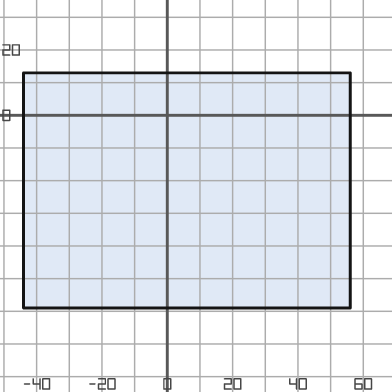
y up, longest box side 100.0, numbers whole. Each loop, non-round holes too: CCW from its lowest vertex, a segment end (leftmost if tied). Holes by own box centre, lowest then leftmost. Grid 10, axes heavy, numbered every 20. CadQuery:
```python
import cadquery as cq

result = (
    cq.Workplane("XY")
    .moveTo(-44.0, -59.0)
    .lineTo(56.0, -59.0)
    .lineTo(56.0, 13.0)
    .lineTo(-44.0, 13.0)
    .close()
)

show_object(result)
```